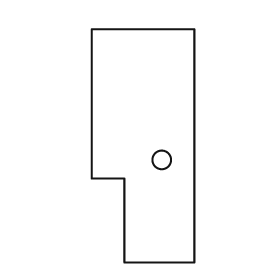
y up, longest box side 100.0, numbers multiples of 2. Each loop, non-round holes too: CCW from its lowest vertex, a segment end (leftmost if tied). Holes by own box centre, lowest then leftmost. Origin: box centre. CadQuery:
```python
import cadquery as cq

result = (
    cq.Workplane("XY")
    .moveTo(-8.0, -50.0)
    .lineTo(22.0, -50.0)
    .lineTo(22.0, 50.0)
    .lineTo(-22.0, 50.0)
    .lineTo(-22.0, -14.0)
    .lineTo(-8.0, -14.0)
    .close()
    .moveTo(8.0, -6.0)
    .circle(4.0)
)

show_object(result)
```